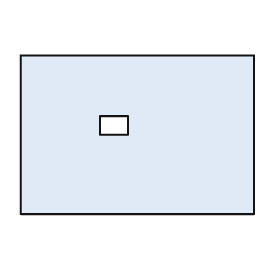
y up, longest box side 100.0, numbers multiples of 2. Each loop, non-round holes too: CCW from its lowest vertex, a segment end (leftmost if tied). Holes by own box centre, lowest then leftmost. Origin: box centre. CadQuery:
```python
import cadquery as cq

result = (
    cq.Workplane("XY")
    .moveTo(-50.0, -34.0)
    .lineTo(50.0, -34.0)
    .lineTo(50.0, 34.0)
    .lineTo(-50.0, 34.0)
    .close()
    .moveTo(-16.0, 0.0)
    .lineTo(-4.0, 0.0)
    .lineTo(-4.0, 8.0)
    .lineTo(-16.0, 8.0)
    .close()
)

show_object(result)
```